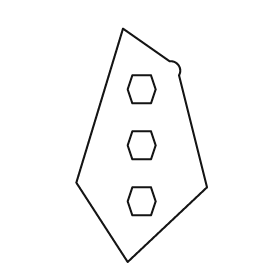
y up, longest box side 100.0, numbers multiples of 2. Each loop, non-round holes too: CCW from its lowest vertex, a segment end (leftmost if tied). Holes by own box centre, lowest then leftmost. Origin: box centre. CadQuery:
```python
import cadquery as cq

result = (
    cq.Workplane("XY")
    .moveTo(-6.0, -50.0)
    .lineTo(28.0, -18.0)
    .lineTo(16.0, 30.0)
    .threePointArc((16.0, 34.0), (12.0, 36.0))
    .lineTo(-8.0, 50.0)
    .lineTo(-28.0, -16.0)
    .close()
    .moveTo(-4.0, -30.0)
    .lineTo(4.0, -30.0)
    .lineTo(6.0, -24.0)
    .lineTo(4.0, -18.0)
    .lineTo(-4.0, -18.0)
    .lineTo(-6.0, -24.0)
    .close()
    .moveTo(-4.0, -6.0)
    .lineTo(4.0, -6.0)
    .lineTo(6.0, 0.0)
    .lineTo(4.0, 6.0)
    .lineTo(-4.0, 6.0)
    .lineTo(-6.0, 0.0)
    .close()
    .moveTo(-4.0, 18.0)
    .lineTo(4.0, 18.0)
    .lineTo(6.0, 24.0)
    .lineTo(4.0, 30.0)
    .lineTo(-4.0, 30.0)
    .lineTo(-6.0, 24.0)
    .close()
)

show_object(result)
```